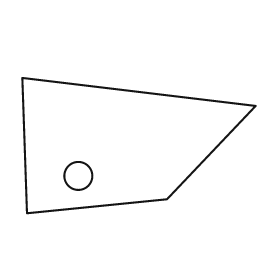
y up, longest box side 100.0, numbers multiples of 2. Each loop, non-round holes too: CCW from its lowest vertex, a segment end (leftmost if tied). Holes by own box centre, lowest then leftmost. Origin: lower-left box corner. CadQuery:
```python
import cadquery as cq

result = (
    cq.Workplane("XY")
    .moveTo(2.0, 0.0)
    .lineTo(62.0, 6.0)
    .lineTo(100.0, 46.0)
    .lineTo(0.0, 58.0)
    .close()
    .moveTo(24.0, 16.0)
    .circle(6.0)
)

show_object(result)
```